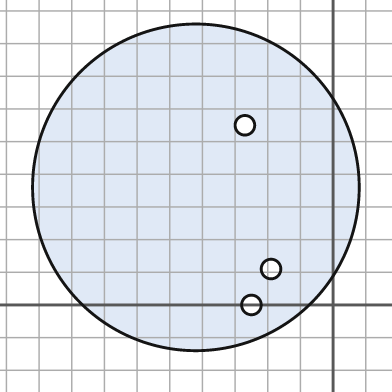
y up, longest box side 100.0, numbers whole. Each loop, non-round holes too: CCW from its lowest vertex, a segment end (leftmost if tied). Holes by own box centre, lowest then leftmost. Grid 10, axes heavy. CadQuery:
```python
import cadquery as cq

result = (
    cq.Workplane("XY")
    .moveTo(-42.0, 36.0)
    .circle(50.0)
    .moveTo(-25.0, 0.0)
    .circle(3.0)
    .moveTo(-19.0, 11.0)
    .circle(3.0)
    .moveTo(-27.0, 55.0)
    .circle(3.0)
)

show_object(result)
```